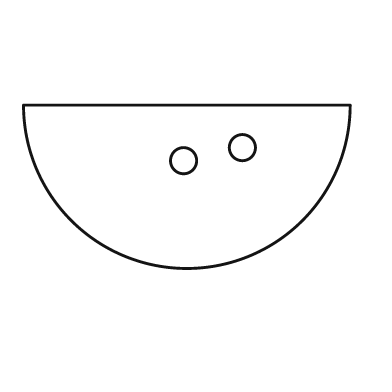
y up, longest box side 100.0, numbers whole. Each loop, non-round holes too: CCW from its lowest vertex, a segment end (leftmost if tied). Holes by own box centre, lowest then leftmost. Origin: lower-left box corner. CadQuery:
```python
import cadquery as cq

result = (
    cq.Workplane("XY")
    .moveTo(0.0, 50.0)
    .threePointArc((50.0, 0.0), (100.0, 50.0))
    .close()
    .moveTo(49.0, 33.0)
    .circle(4.0)
    .moveTo(67.0, 37.0)
    .circle(4.0)
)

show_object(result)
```